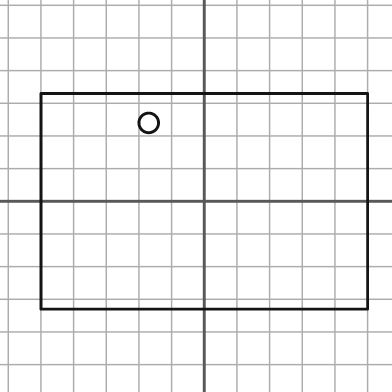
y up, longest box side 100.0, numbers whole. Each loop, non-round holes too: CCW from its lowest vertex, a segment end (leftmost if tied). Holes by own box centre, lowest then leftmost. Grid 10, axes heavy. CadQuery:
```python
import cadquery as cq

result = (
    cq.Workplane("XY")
    .moveTo(-50.0, -33.0)
    .lineTo(50.0, -33.0)
    .lineTo(50.0, 33.0)
    .lineTo(-50.0, 33.0)
    .close()
    .moveTo(-17.0, 24.0)
    .circle(3.0)
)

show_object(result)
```